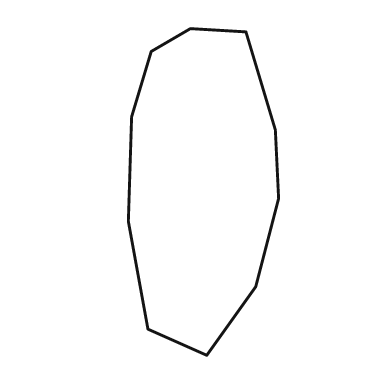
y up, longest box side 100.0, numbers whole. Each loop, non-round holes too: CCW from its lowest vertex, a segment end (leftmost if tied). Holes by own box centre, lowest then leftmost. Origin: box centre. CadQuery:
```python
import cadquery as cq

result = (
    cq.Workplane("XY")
    .moveTo(1.0, -50.0)
    .lineTo(16.0, -29.0)
    .lineTo(23.0, -2.0)
    .lineTo(22.0, 19.0)
    .lineTo(13.0, 49.0)
    .lineTo(-4.0, 50.0)
    .lineTo(-16.0, 43.0)
    .lineTo(-22.0, 23.0)
    .lineTo(-23.0, -9.0)
    .lineTo(-17.0, -42.0)
    .close()
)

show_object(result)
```